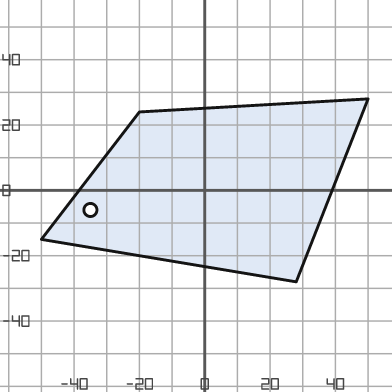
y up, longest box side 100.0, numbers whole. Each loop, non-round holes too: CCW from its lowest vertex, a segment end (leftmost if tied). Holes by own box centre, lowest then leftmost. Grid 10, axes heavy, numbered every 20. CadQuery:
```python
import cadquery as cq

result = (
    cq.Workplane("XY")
    .moveTo(28.0, -28.0)
    .lineTo(50.0, 28.0)
    .lineTo(-20.0, 24.0)
    .lineTo(-50.0, -15.0)
    .close()
    .moveTo(-35.0, -6.0)
    .circle(2.0)
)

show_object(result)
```